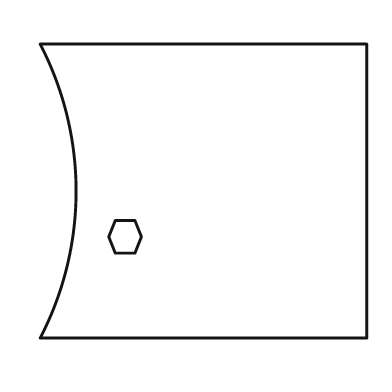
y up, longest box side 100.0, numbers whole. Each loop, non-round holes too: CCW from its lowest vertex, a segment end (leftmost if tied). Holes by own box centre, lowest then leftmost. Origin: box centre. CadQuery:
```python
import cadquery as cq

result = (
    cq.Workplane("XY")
    .moveTo(-50.0, -45.0)
    .lineTo(50.0, -45.0)
    .lineTo(50.0, 45.0)
    .lineTo(-50.0, 45.0)
    .threePointArc((-39.0, 0.0), (-50.0, -45.0))
    .close()
    .moveTo(-27.0, -19.0)
    .lineTo(-21.0, -19.0)
    .lineTo(-19.0, -14.0)
    .lineTo(-21.0, -9.0)
    .lineTo(-27.0, -9.0)
    .lineTo(-29.0, -14.0)
    .close()
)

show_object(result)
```